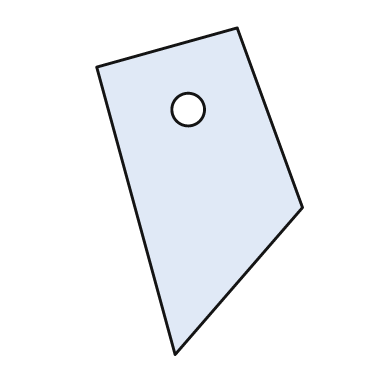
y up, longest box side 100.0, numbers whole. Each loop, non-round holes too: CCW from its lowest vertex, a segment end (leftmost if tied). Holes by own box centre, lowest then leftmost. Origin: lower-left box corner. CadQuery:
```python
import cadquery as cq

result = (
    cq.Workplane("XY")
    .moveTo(24.0, 0.0)
    .lineTo(63.0, 45.0)
    .lineTo(43.0, 100.0)
    .lineTo(0.0, 88.0)
    .close()
    .moveTo(28.0, 75.0)
    .circle(5.0)
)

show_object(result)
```